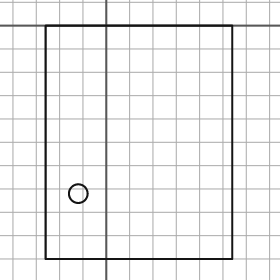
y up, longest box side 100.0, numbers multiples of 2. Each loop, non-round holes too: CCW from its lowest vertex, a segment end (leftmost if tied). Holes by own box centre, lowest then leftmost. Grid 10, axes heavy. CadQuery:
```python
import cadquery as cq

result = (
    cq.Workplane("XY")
    .moveTo(-26.0, -100.0)
    .lineTo(54.0, -100.0)
    .lineTo(54.0, 0.0)
    .lineTo(-26.0, 0.0)
    .close()
    .moveTo(-12.0, -72.0)
    .circle(4.0)
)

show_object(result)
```